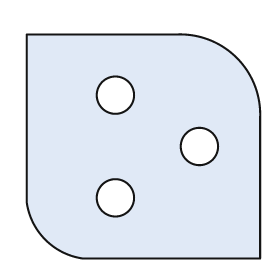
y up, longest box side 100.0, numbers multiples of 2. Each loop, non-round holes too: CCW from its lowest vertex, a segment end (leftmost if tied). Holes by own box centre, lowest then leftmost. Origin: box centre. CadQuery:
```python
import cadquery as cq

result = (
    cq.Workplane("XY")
    .moveTo(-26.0, -48.0)
    .lineTo(50.0, -48.0)
    .lineTo(50.0, 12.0)
    .threePointArc((40.0, 38.0), (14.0, 48.0))
    .lineTo(-50.0, 48.0)
    .lineTo(-50.0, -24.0)
    .threePointArc((-42.0, -40.0), (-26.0, -48.0))
    .close()
    .moveTo(-12.0, -22.0)
    .circle(8.0)
    .moveTo(24.0, 0.0)
    .circle(8.0)
    .moveTo(-12.0, 22.0)
    .circle(8.0)
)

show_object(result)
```